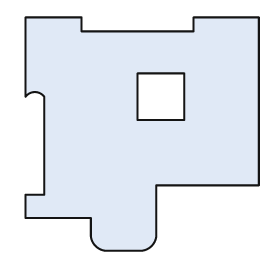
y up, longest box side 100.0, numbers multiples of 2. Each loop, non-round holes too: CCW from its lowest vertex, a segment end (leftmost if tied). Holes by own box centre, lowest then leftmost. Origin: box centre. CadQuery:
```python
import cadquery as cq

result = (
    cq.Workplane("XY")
    .moveTo(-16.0, -50.0)
    .lineTo(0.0, -50.0)
    .threePointArc((4.0, -48.0), (6.0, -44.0))
    .lineTo(6.0, -22.0)
    .lineTo(50.0, -22.0)
    .lineTo(50.0, 50.0)
    .lineTo(22.0, 50.0)
    .lineTo(22.0, 44.0)
    .lineTo(-26.0, 44.0)
    .lineTo(-26.0, 50.0)
    .lineTo(-50.0, 50.0)
    .lineTo(-50.0, 16.0)
    .threePointArc((-46.0, 18.0), (-42.0, 16.0))
    .lineTo(-42.0, -26.0)
    .lineTo(-50.0, -26.0)
    .lineTo(-50.0, -36.0)
    .lineTo(-22.0, -36.0)
    .lineTo(-22.0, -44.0)
    .threePointArc((-20.0, -48.0), (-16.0, -50.0))
    .close()
    .moveTo(-2.0, 6.0)
    .lineTo(18.0, 6.0)
    .lineTo(18.0, 26.0)
    .lineTo(-2.0, 26.0)
    .close()
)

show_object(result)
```